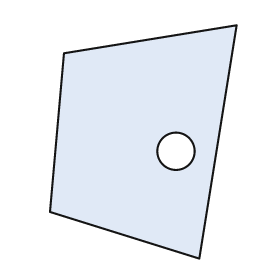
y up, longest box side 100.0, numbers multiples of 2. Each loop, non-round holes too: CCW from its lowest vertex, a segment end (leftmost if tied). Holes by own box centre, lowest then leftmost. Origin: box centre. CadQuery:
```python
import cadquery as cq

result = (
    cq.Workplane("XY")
    .moveTo(24.0, -50.0)
    .lineTo(40.0, 50.0)
    .lineTo(-34.0, 38.0)
    .lineTo(-40.0, -30.0)
    .close()
    .moveTo(14.0, -4.0)
    .circle(8.0)
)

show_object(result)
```